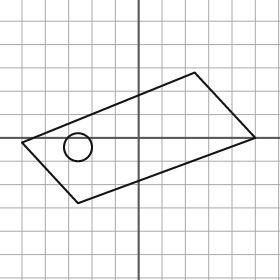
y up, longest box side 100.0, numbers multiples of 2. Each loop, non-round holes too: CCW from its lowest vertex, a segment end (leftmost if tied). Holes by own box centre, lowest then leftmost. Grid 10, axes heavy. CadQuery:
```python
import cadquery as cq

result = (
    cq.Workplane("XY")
    .moveTo(-26.0, -28.0)
    .lineTo(50.0, 0.0)
    .lineTo(24.0, 28.0)
    .lineTo(-50.0, -2.0)
    .close()
    .moveTo(-26.0, -4.0)
    .circle(6.0)
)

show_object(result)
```